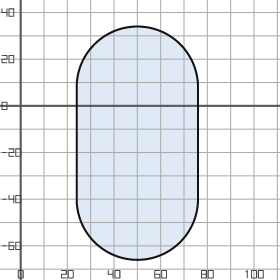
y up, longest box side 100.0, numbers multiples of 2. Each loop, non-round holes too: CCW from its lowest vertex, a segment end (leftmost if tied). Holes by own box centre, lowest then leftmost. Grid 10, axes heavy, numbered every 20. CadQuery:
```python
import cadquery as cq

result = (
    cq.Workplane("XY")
    .moveTo(24.0, -40.0)
    .threePointArc((50.0, -66.0), (76.0, -40.0))
    .lineTo(76.0, 8.0)
    .threePointArc((50.0, 34.0), (24.0, 8.0))
    .close()
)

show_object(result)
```